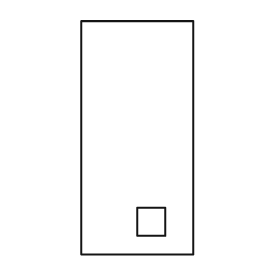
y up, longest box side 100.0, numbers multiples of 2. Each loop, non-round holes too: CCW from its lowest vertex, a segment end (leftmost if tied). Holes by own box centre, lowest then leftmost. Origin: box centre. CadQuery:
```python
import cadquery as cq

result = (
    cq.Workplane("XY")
    .moveTo(-24.0, -50.0)
    .lineTo(24.0, -50.0)
    .lineTo(24.0, 50.0)
    .lineTo(-24.0, 50.0)
    .close()
    .moveTo(0.0, -42.0)
    .lineTo(12.0, -42.0)
    .lineTo(12.0, -30.0)
    .lineTo(0.0, -30.0)
    .close()
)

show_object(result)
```